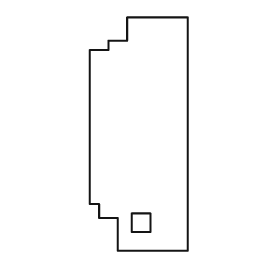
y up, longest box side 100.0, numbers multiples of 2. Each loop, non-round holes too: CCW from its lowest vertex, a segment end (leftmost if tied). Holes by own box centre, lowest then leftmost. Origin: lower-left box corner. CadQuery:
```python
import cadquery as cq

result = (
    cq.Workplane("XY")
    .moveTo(12.0, 0.0)
    .lineTo(42.0, 0.0)
    .lineTo(42.0, 100.0)
    .lineTo(16.0, 100.0)
    .lineTo(16.0, 90.0)
    .lineTo(8.0, 90.0)
    .lineTo(8.0, 86.0)
    .lineTo(0.0, 86.0)
    .lineTo(0.0, 20.0)
    .lineTo(4.0, 20.0)
    .lineTo(4.0, 14.0)
    .lineTo(12.0, 14.0)
    .close()
    .moveTo(18.0, 8.0)
    .lineTo(26.0, 8.0)
    .lineTo(26.0, 16.0)
    .lineTo(18.0, 16.0)
    .close()
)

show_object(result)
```